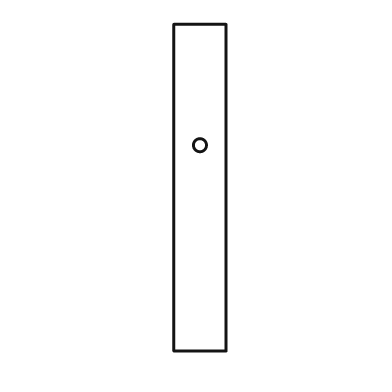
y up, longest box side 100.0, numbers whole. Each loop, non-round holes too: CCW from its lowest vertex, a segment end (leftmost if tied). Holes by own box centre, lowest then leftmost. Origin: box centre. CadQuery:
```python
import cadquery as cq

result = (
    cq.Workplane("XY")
    .moveTo(-8.0, -50.0)
    .lineTo(8.0, -50.0)
    .lineTo(8.0, 50.0)
    .lineTo(-8.0, 50.0)
    .close()
    .moveTo(0.0, 13.0)
    .circle(2.0)
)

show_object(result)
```